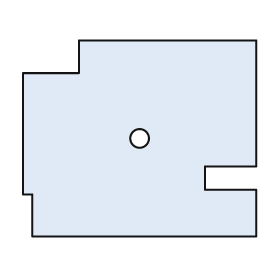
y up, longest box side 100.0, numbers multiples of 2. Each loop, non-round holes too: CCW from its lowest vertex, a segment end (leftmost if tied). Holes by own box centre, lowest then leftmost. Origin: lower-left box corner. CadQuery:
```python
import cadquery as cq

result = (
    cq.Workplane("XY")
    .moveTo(4.0, 0.0)
    .lineTo(100.0, 0.0)
    .lineTo(100.0, 20.0)
    .lineTo(78.0, 20.0)
    .lineTo(78.0, 30.0)
    .lineTo(100.0, 30.0)
    .lineTo(100.0, 84.0)
    .lineTo(24.0, 84.0)
    .lineTo(24.0, 70.0)
    .lineTo(0.0, 70.0)
    .lineTo(0.0, 18.0)
    .lineTo(4.0, 18.0)
    .close()
    .moveTo(50.0, 42.0)
    .circle(4.0)
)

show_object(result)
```